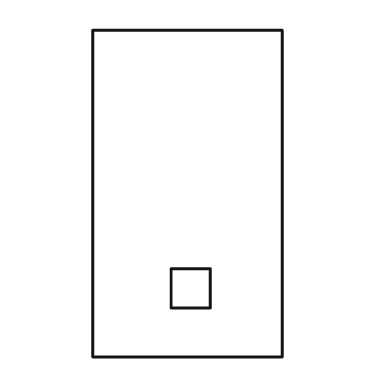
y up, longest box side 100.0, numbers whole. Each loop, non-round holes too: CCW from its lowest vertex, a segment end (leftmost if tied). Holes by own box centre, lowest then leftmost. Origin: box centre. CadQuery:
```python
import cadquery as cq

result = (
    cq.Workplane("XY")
    .moveTo(-29.0, -50.0)
    .lineTo(29.0, -50.0)
    .lineTo(29.0, 50.0)
    .lineTo(-29.0, 50.0)
    .close()
    .moveTo(-5.0, -35.0)
    .lineTo(7.0, -35.0)
    .lineTo(7.0, -23.0)
    .lineTo(-5.0, -23.0)
    .close()
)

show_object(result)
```